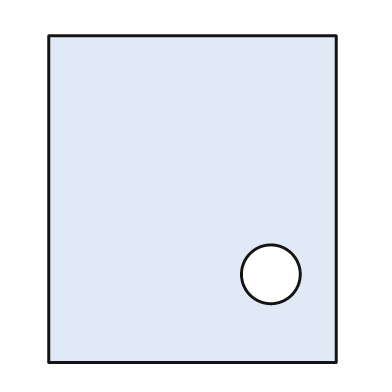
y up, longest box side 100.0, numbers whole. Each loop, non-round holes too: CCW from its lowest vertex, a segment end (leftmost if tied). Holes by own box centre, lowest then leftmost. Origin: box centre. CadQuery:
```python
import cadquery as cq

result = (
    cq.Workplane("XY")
    .moveTo(-44.0, -50.0)
    .lineTo(44.0, -50.0)
    .lineTo(44.0, 50.0)
    .lineTo(-44.0, 50.0)
    .close()
    .moveTo(24.0, -23.0)
    .circle(9.0)
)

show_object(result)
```